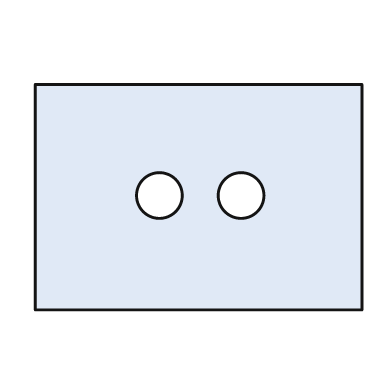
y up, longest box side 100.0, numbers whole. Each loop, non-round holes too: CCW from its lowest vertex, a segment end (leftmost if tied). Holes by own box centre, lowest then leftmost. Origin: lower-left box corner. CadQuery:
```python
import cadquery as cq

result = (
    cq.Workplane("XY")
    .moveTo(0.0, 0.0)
    .lineTo(100.0, 0.0)
    .lineTo(100.0, 69.0)
    .lineTo(0.0, 69.0)
    .close()
    .moveTo(38.0, 35.0)
    .circle(7.0)
    .moveTo(63.0, 35.0)
    .circle(7.0)
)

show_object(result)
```